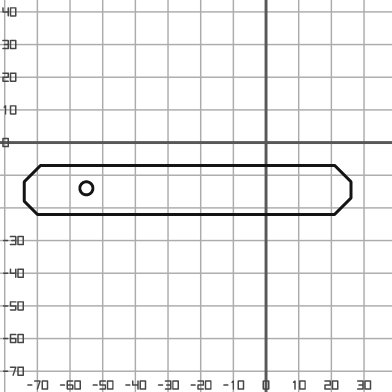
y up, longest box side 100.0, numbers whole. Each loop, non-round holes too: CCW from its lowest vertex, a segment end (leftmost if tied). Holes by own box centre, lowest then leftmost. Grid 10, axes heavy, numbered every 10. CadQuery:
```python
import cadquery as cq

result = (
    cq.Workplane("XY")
    .moveTo(-70.0, -22.0)
    .lineTo(21.0, -22.0)
    .lineTo(26.0, -17.0)
    .lineTo(26.0, -12.0)
    .lineTo(21.0, -7.0)
    .lineTo(-69.0, -7.0)
    .lineTo(-74.0, -12.0)
    .lineTo(-74.0, -18.0)
    .close()
    .moveTo(-55.0, -14.0)
    .circle(2.0)
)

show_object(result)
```